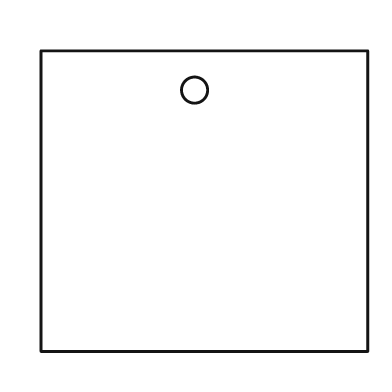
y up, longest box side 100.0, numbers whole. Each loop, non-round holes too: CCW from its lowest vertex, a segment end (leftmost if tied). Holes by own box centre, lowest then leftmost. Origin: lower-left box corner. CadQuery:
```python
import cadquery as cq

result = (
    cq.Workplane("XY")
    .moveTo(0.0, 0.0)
    .lineTo(100.0, 0.0)
    .lineTo(100.0, 92.0)
    .lineTo(0.0, 92.0)
    .close()
    .moveTo(47.0, 80.0)
    .circle(4.0)
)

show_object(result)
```